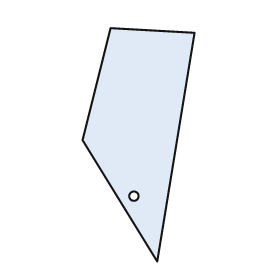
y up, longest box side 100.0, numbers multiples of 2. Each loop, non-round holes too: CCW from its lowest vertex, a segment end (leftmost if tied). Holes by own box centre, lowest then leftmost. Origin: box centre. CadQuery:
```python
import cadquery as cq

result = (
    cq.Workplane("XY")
    .moveTo(8.0, -50.0)
    .lineTo(24.0, 48.0)
    .lineTo(-12.0, 50.0)
    .lineTo(-24.0, 2.0)
    .close()
    .moveTo(-2.0, -22.0)
    .circle(2.0)
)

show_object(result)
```